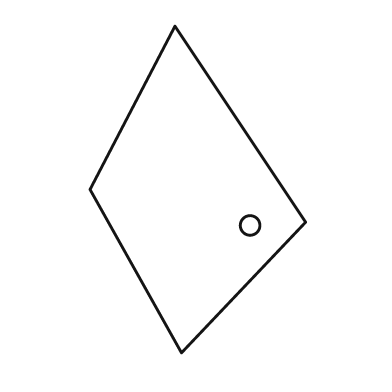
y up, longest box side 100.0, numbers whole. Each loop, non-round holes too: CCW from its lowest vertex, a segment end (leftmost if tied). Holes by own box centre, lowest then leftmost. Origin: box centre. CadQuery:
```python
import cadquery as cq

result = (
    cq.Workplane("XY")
    .moveTo(-5.0, -50.0)
    .lineTo(33.0, -10.0)
    .lineTo(-7.0, 50.0)
    .lineTo(-33.0, 0.0)
    .close()
    .moveTo(16.0, -11.0)
    .circle(3.0)
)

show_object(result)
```